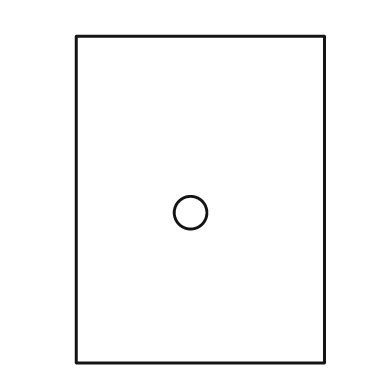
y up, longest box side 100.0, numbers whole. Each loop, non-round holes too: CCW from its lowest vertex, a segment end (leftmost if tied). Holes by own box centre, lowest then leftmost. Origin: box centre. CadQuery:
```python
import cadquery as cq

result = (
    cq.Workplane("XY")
    .moveTo(-38.0, -50.0)
    .lineTo(38.0, -50.0)
    .lineTo(38.0, 50.0)
    .lineTo(-38.0, 50.0)
    .close()
    .moveTo(-3.0, -4.0)
    .circle(5.0)
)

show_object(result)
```